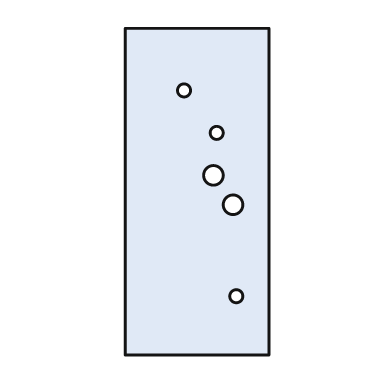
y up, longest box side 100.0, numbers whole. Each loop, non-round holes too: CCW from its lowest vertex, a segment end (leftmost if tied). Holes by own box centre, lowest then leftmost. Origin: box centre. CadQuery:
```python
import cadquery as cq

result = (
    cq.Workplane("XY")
    .moveTo(-22.0, -50.0)
    .lineTo(22.0, -50.0)
    .lineTo(22.0, 50.0)
    .lineTo(-22.0, 50.0)
    .close()
    .moveTo(12.0, -32.0)
    .circle(2.0)
    .moveTo(11.0, -4.0)
    .circle(3.0)
    .moveTo(5.0, 5.0)
    .circle(3.0)
    .moveTo(6.0, 18.0)
    .circle(2.0)
    .moveTo(-4.0, 31.0)
    .circle(2.0)
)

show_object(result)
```